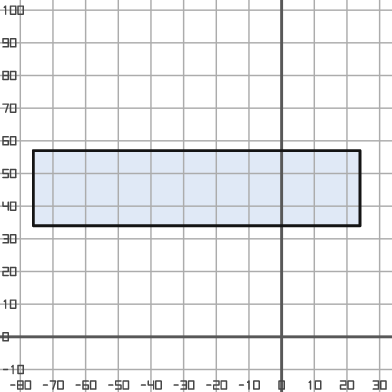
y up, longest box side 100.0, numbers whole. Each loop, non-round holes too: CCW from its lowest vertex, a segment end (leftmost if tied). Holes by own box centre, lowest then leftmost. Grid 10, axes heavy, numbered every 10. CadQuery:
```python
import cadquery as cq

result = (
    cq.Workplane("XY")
    .moveTo(-76.0, 34.0)
    .lineTo(24.0, 34.0)
    .lineTo(24.0, 57.0)
    .lineTo(-76.0, 57.0)
    .close()
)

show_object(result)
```